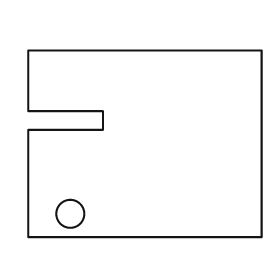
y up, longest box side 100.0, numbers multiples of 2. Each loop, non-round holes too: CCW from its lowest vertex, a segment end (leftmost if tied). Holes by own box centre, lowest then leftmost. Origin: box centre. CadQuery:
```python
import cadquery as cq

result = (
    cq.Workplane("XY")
    .moveTo(-50.0, -40.0)
    .lineTo(50.0, -40.0)
    .lineTo(50.0, 40.0)
    .lineTo(-50.0, 40.0)
    .lineTo(-50.0, 14.0)
    .lineTo(-18.0, 14.0)
    .lineTo(-18.0, 6.0)
    .lineTo(-50.0, 6.0)
    .close()
    .moveTo(-32.0, -30.0)
    .circle(6.0)
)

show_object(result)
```